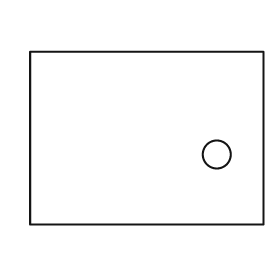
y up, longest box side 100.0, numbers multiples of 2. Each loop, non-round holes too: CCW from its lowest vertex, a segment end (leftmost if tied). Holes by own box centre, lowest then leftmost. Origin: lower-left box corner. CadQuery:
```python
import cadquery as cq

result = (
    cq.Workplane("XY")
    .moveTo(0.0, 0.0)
    .lineTo(100.0, 0.0)
    .lineTo(100.0, 74.0)
    .lineTo(0.0, 74.0)
    .close()
    .moveTo(80.0, 30.0)
    .circle(6.0)
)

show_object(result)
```